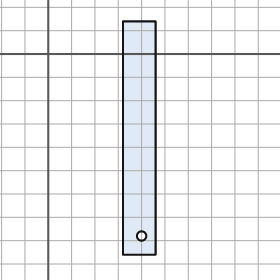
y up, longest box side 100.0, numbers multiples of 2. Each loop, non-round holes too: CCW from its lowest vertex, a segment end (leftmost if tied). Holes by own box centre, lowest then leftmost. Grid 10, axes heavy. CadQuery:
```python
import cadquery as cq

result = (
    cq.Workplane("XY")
    .moveTo(32.0, -86.0)
    .lineTo(46.0, -86.0)
    .lineTo(46.0, 14.0)
    .lineTo(32.0, 14.0)
    .close()
    .moveTo(40.0, -78.0)
    .circle(2.0)
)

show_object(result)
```